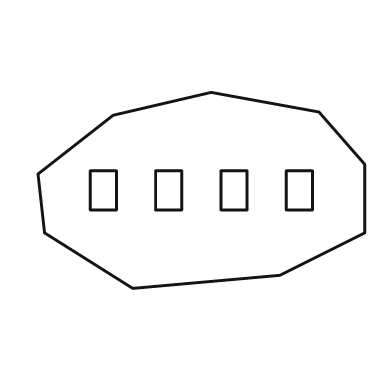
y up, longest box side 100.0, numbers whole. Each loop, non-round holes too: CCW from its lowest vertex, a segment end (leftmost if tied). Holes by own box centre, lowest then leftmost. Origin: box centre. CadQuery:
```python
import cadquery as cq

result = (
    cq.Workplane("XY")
    .moveTo(-21.0, -30.0)
    .lineTo(24.0, -26.0)
    .lineTo(50.0, -13.0)
    .lineTo(50.0, 8.0)
    .lineTo(36.0, 24.0)
    .lineTo(3.0, 30.0)
    .lineTo(-27.0, 23.0)
    .lineTo(-50.0, 5.0)
    .lineTo(-48.0, -13.0)
    .close()
    .moveTo(-34.0, -6.0)
    .lineTo(-26.0, -6.0)
    .lineTo(-26.0, 6.0)
    .lineTo(-34.0, 6.0)
    .close()
    .moveTo(-14.0, -6.0)
    .lineTo(-6.0, -6.0)
    .lineTo(-6.0, 6.0)
    .lineTo(-14.0, 6.0)
    .close()
    .moveTo(6.0, -6.0)
    .lineTo(14.0, -6.0)
    .lineTo(14.0, 6.0)
    .lineTo(6.0, 6.0)
    .close()
    .moveTo(26.0, -6.0)
    .lineTo(34.0, -6.0)
    .lineTo(34.0, 6.0)
    .lineTo(26.0, 6.0)
    .close()
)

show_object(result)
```